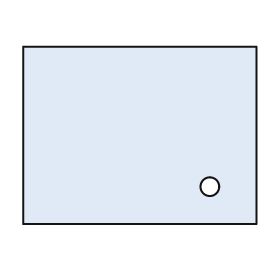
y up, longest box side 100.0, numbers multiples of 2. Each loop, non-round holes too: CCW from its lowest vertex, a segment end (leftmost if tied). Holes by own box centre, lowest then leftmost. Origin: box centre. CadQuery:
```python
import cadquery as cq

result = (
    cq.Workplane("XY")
    .moveTo(-50.0, -38.0)
    .lineTo(50.0, -38.0)
    .lineTo(50.0, 38.0)
    .lineTo(-50.0, 38.0)
    .close()
    .moveTo(30.0, -22.0)
    .circle(4.0)
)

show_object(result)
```